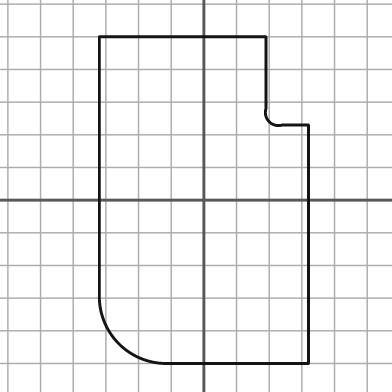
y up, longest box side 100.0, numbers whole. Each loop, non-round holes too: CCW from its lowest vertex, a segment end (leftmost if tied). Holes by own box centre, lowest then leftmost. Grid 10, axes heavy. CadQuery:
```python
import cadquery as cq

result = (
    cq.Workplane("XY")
    .moveTo(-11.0, -50.0)
    .lineTo(32.0, -50.0)
    .lineTo(32.0, 23.0)
    .lineTo(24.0, 23.0)
    .threePointArc((20.0, 24.0), (19.0, 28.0))
    .lineTo(19.0, 50.0)
    .lineTo(-32.0, 50.0)
    .lineTo(-32.0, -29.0)
    .threePointArc((-26.0, -44.0), (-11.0, -50.0))
    .close()
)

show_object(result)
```